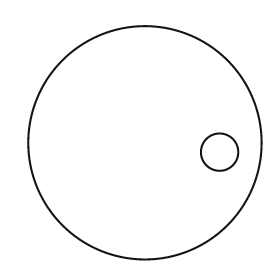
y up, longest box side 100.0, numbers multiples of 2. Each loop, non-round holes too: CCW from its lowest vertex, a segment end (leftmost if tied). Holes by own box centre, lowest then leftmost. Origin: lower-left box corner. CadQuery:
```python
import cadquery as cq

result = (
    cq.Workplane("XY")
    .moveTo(50.0, 50.0)
    .circle(50.0)
    .moveTo(82.0, 46.0)
    .circle(8.0)
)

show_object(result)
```